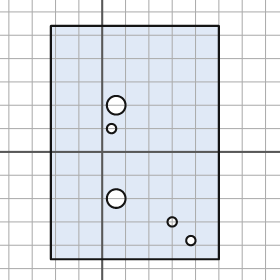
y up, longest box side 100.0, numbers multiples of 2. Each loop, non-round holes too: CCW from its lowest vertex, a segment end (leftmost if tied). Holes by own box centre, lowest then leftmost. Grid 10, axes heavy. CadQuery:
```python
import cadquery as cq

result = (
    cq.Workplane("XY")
    .moveTo(-22.0, -46.0)
    .lineTo(50.0, -46.0)
    .lineTo(50.0, 54.0)
    .lineTo(-22.0, 54.0)
    .close()
    .moveTo(38.0, -38.0)
    .circle(2.0)
    .moveTo(30.0, -30.0)
    .circle(2.0)
    .moveTo(6.0, -20.0)
    .circle(4.0)
    .moveTo(4.0, 10.0)
    .circle(2.0)
    .moveTo(6.0, 20.0)
    .circle(4.0)
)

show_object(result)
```